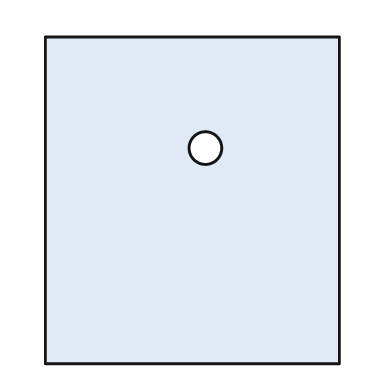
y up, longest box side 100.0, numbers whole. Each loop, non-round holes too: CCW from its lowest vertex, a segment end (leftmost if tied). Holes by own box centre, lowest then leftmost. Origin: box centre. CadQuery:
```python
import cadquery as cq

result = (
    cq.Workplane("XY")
    .moveTo(-45.0, -50.0)
    .lineTo(45.0, -50.0)
    .lineTo(45.0, 50.0)
    .lineTo(-45.0, 50.0)
    .close()
    .moveTo(4.0, 16.0)
    .circle(5.0)
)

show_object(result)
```